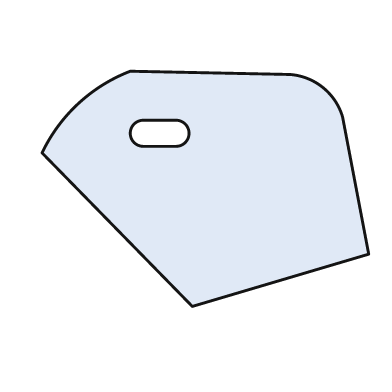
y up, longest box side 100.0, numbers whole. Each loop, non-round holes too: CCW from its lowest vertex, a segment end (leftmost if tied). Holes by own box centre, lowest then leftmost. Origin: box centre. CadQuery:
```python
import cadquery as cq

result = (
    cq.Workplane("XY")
    .moveTo(-4.0, -36.0)
    .lineTo(50.0, -20.0)
    .lineTo(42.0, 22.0)
    .threePointArc((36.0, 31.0), (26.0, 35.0))
    .lineTo(-23.0, 36.0)
    .threePointArc((-39.0, 26.0), (-50.0, 11.0))
    .close()
    .moveTo(-19.0, 13.0)
    .lineTo(-9.0, 13.0)
    .threePointArc((-5.0, 17.0), (-9.0, 21.0))
    .lineTo(-19.0, 21.0)
    .threePointArc((-23.0, 17.0), (-19.0, 13.0))
    .close()
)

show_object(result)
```